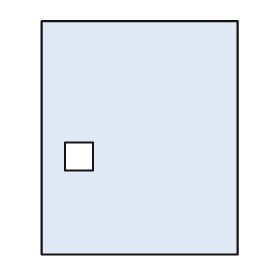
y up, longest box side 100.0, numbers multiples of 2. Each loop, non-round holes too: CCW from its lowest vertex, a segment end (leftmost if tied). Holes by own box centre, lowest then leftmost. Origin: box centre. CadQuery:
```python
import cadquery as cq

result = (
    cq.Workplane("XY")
    .moveTo(-42.0, -50.0)
    .lineTo(42.0, -50.0)
    .lineTo(42.0, 50.0)
    .lineTo(-42.0, 50.0)
    .close()
    .moveTo(-32.0, -14.0)
    .lineTo(-20.0, -14.0)
    .lineTo(-20.0, -2.0)
    .lineTo(-32.0, -2.0)
    .close()
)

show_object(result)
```